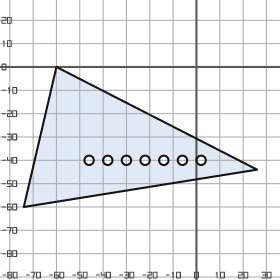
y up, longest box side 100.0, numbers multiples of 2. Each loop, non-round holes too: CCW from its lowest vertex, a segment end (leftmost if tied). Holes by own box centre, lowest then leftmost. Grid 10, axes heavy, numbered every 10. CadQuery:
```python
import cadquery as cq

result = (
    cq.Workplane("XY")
    .moveTo(-74.0, -60.0)
    .lineTo(26.0, -44.0)
    .lineTo(-60.0, 0.0)
    .close()
    .moveTo(-46.0, -40.0)
    .circle(2.0)
    .moveTo(-38.0, -40.0)
    .circle(2.0)
    .moveTo(-30.0, -40.0)
    .circle(2.0)
    .moveTo(-22.0, -40.0)
    .circle(2.0)
    .moveTo(-14.0, -40.0)
    .circle(2.0)
    .moveTo(-6.0, -40.0)
    .circle(2.0)
    .moveTo(2.0, -40.0)
    .circle(2.0)
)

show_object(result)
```